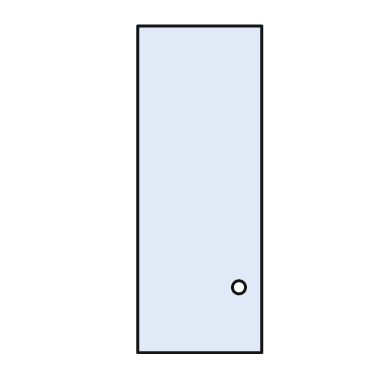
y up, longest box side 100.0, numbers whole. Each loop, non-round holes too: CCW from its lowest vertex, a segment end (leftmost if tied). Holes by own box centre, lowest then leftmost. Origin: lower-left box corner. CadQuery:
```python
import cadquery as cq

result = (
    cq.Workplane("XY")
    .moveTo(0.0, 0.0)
    .lineTo(38.0, 0.0)
    .lineTo(38.0, 100.0)
    .lineTo(0.0, 100.0)
    .close()
    .moveTo(31.0, 20.0)
    .circle(2.0)
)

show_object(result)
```